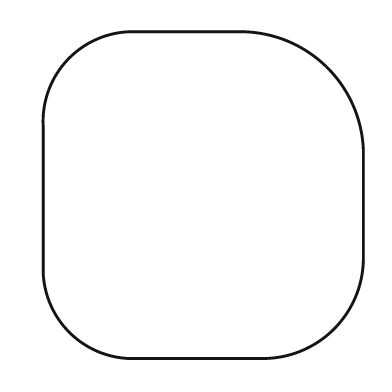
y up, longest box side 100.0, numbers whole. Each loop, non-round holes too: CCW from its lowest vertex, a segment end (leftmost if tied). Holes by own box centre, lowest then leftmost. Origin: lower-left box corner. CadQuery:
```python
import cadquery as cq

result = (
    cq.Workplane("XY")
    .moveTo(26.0, 0.0)
    .lineTo(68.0, 0.0)
    .threePointArc((89.0, 9.0), (98.0, 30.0))
    .lineTo(98.0, 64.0)
    .threePointArc((87.0, 89.0), (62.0, 100.0))
    .lineTo(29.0, 100.0)
    .threePointArc((8.0, 92.0), (0.0, 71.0))
    .lineTo(0.0, 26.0)
    .threePointArc((8.0, 8.0), (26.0, 0.0))
    .close()
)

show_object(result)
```